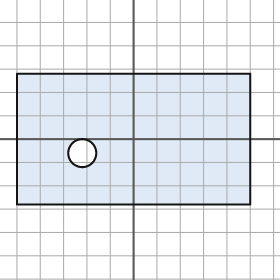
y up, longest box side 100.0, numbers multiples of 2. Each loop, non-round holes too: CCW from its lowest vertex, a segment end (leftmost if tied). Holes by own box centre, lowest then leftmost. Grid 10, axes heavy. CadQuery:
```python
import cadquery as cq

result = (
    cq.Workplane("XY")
    .moveTo(-50.0, -28.0)
    .lineTo(50.0, -28.0)
    .lineTo(50.0, 28.0)
    .lineTo(-50.0, 28.0)
    .close()
    .moveTo(-22.0, -6.0)
    .circle(6.0)
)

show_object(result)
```